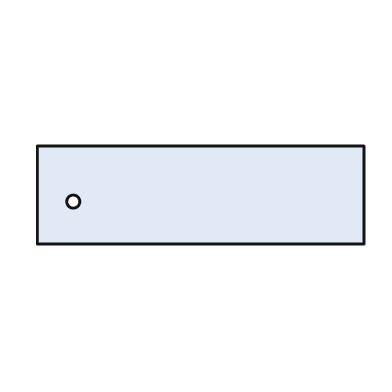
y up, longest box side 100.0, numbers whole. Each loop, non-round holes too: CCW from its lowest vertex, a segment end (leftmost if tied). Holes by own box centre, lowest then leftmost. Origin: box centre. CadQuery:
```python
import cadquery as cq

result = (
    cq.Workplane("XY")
    .moveTo(-50.0, -15.0)
    .lineTo(50.0, -15.0)
    .lineTo(50.0, 15.0)
    .lineTo(-50.0, 15.0)
    .close()
    .moveTo(-39.0, -2.0)
    .circle(2.0)
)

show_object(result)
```